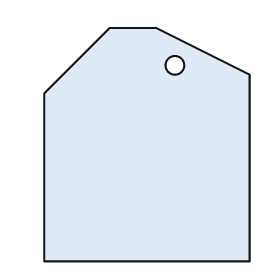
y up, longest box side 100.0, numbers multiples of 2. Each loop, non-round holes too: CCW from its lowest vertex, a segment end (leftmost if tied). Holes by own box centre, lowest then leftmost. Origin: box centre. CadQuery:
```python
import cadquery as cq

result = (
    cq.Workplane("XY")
    .moveTo(-44.0, -50.0)
    .lineTo(44.0, -50.0)
    .lineTo(44.0, 30.0)
    .lineTo(4.0, 50.0)
    .lineTo(-16.0, 50.0)
    .lineTo(-44.0, 22.0)
    .close()
    .moveTo(12.0, 34.0)
    .circle(4.0)
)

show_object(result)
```